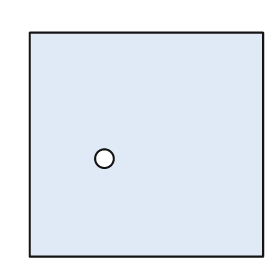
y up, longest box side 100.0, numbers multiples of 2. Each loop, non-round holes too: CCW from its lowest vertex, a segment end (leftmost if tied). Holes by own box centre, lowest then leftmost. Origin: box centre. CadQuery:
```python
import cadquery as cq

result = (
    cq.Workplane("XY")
    .moveTo(-50.0, -48.0)
    .lineTo(50.0, -48.0)
    .lineTo(50.0, 48.0)
    .lineTo(-50.0, 48.0)
    .close()
    .moveTo(-18.0, -6.0)
    .circle(4.0)
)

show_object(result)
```